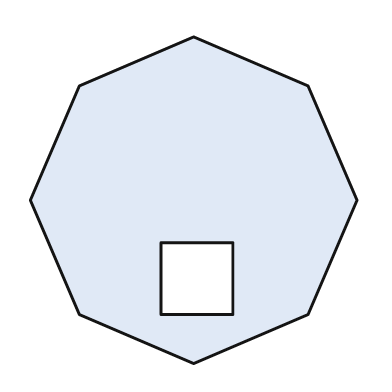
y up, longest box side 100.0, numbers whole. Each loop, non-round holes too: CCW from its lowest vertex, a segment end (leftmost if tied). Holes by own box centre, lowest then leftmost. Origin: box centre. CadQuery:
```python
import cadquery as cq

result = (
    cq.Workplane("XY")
    .moveTo(0.0, -50.0)
    .lineTo(35.0, -35.0)
    .lineTo(50.0, 0.0)
    .lineTo(35.0, 35.0)
    .lineTo(0.0, 50.0)
    .lineTo(-35.0, 35.0)
    .lineTo(-50.0, 0.0)
    .lineTo(-35.0, -35.0)
    .close()
    .moveTo(-10.0, -35.0)
    .lineTo(12.0, -35.0)
    .lineTo(12.0, -13.0)
    .lineTo(-10.0, -13.0)
    .close()
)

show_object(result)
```